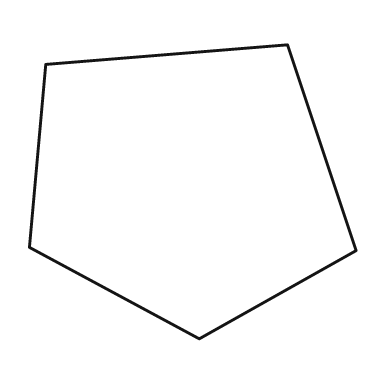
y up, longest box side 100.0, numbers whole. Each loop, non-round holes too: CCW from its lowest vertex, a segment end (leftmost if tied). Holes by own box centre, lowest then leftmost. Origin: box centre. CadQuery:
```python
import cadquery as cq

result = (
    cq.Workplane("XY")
    .moveTo(2.0, -45.0)
    .lineTo(50.0, -18.0)
    .lineTo(29.0, 45.0)
    .lineTo(-45.0, 39.0)
    .lineTo(-50.0, -17.0)
    .close()
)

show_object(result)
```